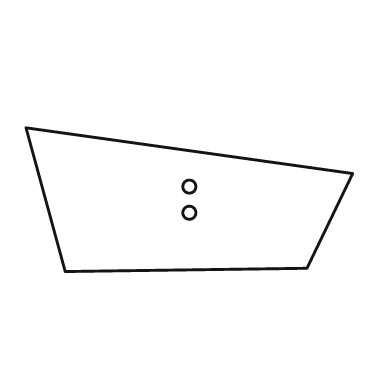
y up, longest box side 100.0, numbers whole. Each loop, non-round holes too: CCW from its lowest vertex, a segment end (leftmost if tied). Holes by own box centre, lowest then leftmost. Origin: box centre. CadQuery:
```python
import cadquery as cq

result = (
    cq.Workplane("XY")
    .moveTo(-38.0, -22.0)
    .lineTo(36.0, -21.0)
    .lineTo(50.0, 8.0)
    .lineTo(-50.0, 22.0)
    .close()
    .moveTo(0.0, -4.0)
    .circle(2.0)
    .moveTo(0.0, 4.0)
    .circle(2.0)
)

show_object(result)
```